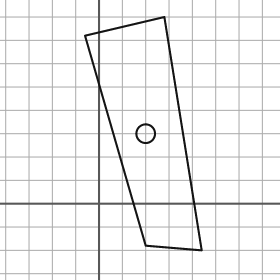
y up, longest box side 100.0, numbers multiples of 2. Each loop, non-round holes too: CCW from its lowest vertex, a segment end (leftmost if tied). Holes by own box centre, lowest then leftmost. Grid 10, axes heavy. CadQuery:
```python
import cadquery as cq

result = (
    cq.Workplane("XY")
    .moveTo(44.0, -20.0)
    .lineTo(28.0, 80.0)
    .lineTo(-6.0, 72.0)
    .lineTo(20.0, -18.0)
    .close()
    .moveTo(20.0, 30.0)
    .circle(4.0)
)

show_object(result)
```